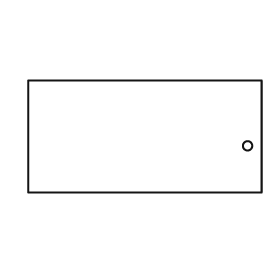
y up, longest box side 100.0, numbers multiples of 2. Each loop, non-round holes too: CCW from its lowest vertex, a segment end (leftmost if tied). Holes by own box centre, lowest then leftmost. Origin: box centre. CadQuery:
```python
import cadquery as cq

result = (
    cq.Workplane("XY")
    .moveTo(-50.0, -24.0)
    .lineTo(50.0, -24.0)
    .lineTo(50.0, 24.0)
    .lineTo(-50.0, 24.0)
    .close()
    .moveTo(44.0, -4.0)
    .circle(2.0)
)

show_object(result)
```